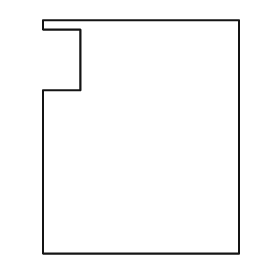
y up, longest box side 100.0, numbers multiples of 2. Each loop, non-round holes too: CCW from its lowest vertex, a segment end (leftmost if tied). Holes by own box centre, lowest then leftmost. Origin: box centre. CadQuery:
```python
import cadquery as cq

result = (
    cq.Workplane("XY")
    .moveTo(-42.0, -50.0)
    .lineTo(42.0, -50.0)
    .lineTo(42.0, 50.0)
    .lineTo(-42.0, 50.0)
    .lineTo(-42.0, 46.0)
    .lineTo(-26.0, 46.0)
    .lineTo(-26.0, 20.0)
    .lineTo(-42.0, 20.0)
    .close()
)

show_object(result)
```